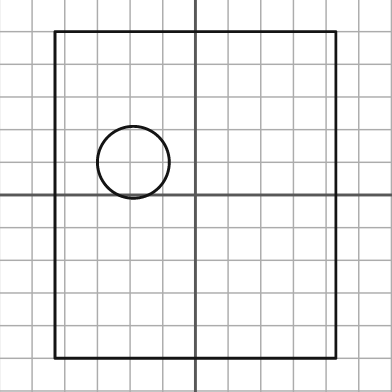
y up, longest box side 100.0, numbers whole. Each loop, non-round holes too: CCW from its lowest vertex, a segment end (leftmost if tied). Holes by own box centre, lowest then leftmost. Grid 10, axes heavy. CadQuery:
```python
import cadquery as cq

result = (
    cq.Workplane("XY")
    .moveTo(-43.0, -50.0)
    .lineTo(43.0, -50.0)
    .lineTo(43.0, 50.0)
    .lineTo(-43.0, 50.0)
    .close()
    .moveTo(-19.0, 10.0)
    .circle(11.0)
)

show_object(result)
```